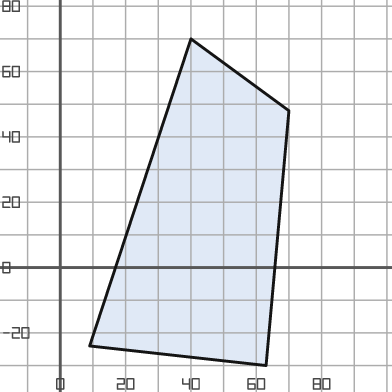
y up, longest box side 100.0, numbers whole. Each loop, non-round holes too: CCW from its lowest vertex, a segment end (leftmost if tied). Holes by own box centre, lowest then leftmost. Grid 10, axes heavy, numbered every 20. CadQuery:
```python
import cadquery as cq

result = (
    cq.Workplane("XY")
    .moveTo(63.0, -30.0)
    .lineTo(70.0, 48.0)
    .lineTo(40.0, 70.0)
    .lineTo(9.0, -24.0)
    .close()
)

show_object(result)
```